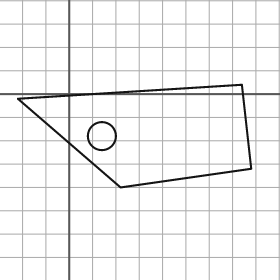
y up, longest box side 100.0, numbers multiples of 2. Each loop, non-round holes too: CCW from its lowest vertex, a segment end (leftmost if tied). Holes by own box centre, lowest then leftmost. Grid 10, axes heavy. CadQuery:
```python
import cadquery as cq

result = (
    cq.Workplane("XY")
    .moveTo(22.0, -40.0)
    .lineTo(78.0, -32.0)
    .lineTo(74.0, 4.0)
    .lineTo(-22.0, -2.0)
    .close()
    .moveTo(14.0, -18.0)
    .circle(6.0)
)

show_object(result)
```